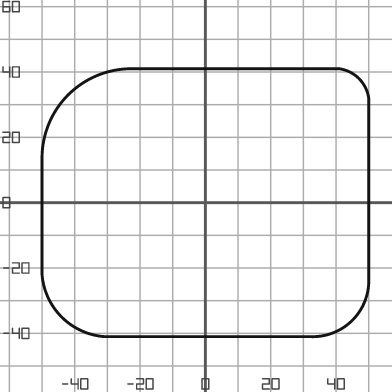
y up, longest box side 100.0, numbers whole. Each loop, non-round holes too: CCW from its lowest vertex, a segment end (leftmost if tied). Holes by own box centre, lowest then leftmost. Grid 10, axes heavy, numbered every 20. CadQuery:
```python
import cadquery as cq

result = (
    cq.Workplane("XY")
    .moveTo(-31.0, -41.0)
    .lineTo(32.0, -41.0)
    .threePointArc((45.0, -36.0), (50.0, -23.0))
    .lineTo(50.0, 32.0)
    .threePointArc((47.0, 38.0), (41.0, 41.0))
    .lineTo(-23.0, 41.0)
    .threePointArc((-42.0, 33.0), (-50.0, 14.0))
    .lineTo(-50.0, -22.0)
    .threePointArc((-44.0, -35.0), (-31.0, -41.0))
    .close()
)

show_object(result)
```